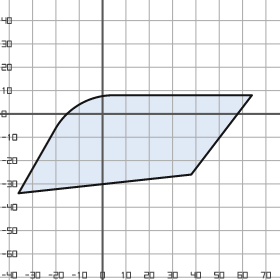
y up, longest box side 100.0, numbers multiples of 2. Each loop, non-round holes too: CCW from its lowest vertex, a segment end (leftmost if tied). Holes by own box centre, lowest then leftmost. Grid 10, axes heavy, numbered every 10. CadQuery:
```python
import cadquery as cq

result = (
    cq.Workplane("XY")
    .moveTo(-36.0, -34.0)
    .lineTo(38.0, -26.0)
    .lineTo(64.0, 8.0)
    .lineTo(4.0, 8.0)
    .threePointArc((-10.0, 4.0), (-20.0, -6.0))
    .close()
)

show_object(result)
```